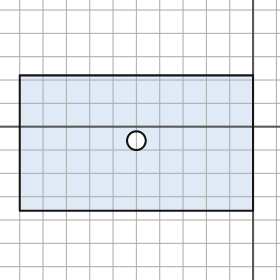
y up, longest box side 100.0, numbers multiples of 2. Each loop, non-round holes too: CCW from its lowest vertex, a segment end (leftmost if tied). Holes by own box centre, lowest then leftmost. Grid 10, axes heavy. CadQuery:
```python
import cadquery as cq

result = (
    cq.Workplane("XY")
    .moveTo(-100.0, -36.0)
    .lineTo(0.0, -36.0)
    .lineTo(0.0, 22.0)
    .lineTo(-100.0, 22.0)
    .close()
    .moveTo(-50.0, -6.0)
    .circle(4.0)
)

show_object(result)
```